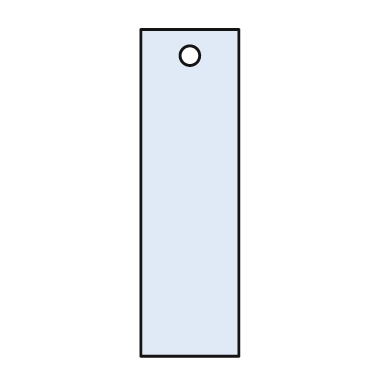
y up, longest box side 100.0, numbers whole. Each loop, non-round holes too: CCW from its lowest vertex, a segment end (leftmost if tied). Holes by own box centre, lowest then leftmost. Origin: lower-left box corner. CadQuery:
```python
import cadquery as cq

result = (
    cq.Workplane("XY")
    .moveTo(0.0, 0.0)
    .lineTo(30.0, 0.0)
    .lineTo(30.0, 100.0)
    .lineTo(0.0, 100.0)
    .close()
    .moveTo(15.0, 92.0)
    .circle(3.0)
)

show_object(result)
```